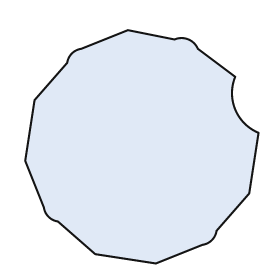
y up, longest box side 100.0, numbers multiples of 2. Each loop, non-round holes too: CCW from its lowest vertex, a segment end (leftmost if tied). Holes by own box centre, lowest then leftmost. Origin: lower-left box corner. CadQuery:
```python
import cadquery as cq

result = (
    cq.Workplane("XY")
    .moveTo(56.0, 0.0)
    .lineTo(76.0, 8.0)
    .threePointArc((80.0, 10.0), (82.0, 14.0))
    .lineTo(96.0, 30.0)
    .lineTo(100.0, 56.0)
    .threePointArc((90.0, 66.0), (90.0, 80.0))
    .lineTo(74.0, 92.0)
    .threePointArc((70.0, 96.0), (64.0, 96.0))
    .lineTo(44.0, 100.0)
    .lineTo(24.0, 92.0)
    .threePointArc((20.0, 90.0), (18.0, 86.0))
    .lineTo(4.0, 70.0)
    .lineTo(0.0, 44.0)
    .lineTo(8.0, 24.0)
    .threePointArc((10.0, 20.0), (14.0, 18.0))
    .lineTo(30.0, 4.0)
    .close()
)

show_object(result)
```